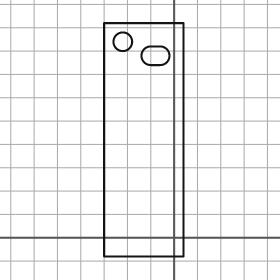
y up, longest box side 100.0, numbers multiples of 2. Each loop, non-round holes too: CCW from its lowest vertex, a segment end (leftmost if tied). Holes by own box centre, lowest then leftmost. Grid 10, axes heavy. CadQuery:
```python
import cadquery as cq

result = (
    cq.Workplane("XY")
    .moveTo(-30.0, -8.0)
    .lineTo(4.0, -8.0)
    .lineTo(4.0, 92.0)
    .lineTo(-30.0, 92.0)
    .close()
    .moveTo(-10.0, 74.0)
    .lineTo(-6.0, 74.0)
    .threePointArc((-2.0, 78.0), (-6.0, 82.0))
    .lineTo(-10.0, 82.0)
    .threePointArc((-14.0, 78.0), (-10.0, 74.0))
    .close()
    .moveTo(-22.0, 84.0)
    .circle(4.0)
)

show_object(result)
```